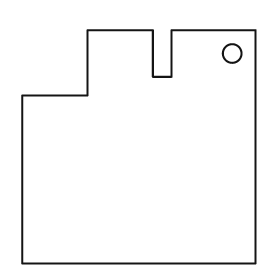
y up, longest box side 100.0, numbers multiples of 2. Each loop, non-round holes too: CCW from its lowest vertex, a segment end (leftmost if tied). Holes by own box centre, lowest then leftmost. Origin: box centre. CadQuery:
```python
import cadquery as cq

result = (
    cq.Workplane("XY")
    .moveTo(-50.0, -50.0)
    .lineTo(50.0, -50.0)
    .lineTo(50.0, 50.0)
    .lineTo(14.0, 50.0)
    .lineTo(14.0, 30.0)
    .lineTo(6.0, 30.0)
    .lineTo(6.0, 50.0)
    .lineTo(-22.0, 50.0)
    .lineTo(-22.0, 22.0)
    .lineTo(-50.0, 22.0)
    .close()
    .moveTo(40.0, 40.0)
    .circle(4.0)
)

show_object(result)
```